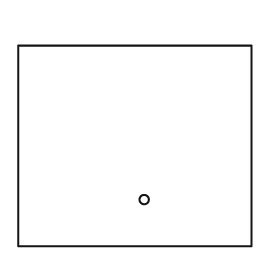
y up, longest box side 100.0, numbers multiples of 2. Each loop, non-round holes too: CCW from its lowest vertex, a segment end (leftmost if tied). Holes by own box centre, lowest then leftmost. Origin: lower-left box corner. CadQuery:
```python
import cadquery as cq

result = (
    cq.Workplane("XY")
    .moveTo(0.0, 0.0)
    .lineTo(100.0, 0.0)
    .lineTo(100.0, 86.0)
    .lineTo(0.0, 86.0)
    .close()
    .moveTo(54.0, 20.0)
    .circle(2.0)
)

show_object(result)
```